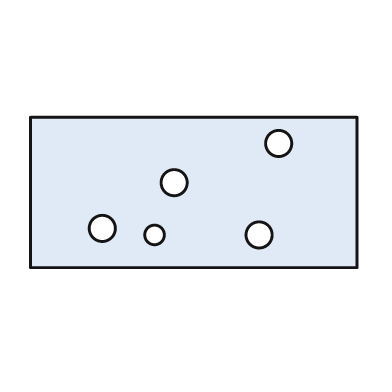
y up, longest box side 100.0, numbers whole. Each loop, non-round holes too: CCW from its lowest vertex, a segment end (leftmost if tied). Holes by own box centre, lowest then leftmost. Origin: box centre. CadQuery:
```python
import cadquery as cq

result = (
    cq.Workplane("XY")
    .moveTo(-50.0, -23.0)
    .lineTo(50.0, -23.0)
    .lineTo(50.0, 23.0)
    .lineTo(-50.0, 23.0)
    .close()
    .moveTo(-12.0, -13.0)
    .circle(3.0)
    .moveTo(20.0, -13.0)
    .circle(4.0)
    .moveTo(-28.0, -11.0)
    .circle(4.0)
    .moveTo(-6.0, 3.0)
    .circle(4.0)
    .moveTo(26.0, 15.0)
    .circle(4.0)
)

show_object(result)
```